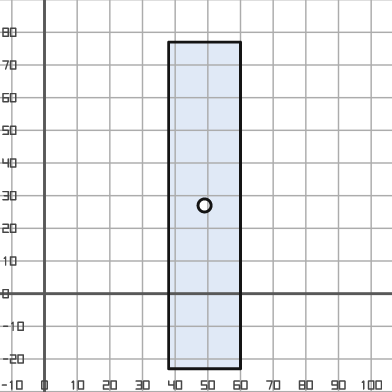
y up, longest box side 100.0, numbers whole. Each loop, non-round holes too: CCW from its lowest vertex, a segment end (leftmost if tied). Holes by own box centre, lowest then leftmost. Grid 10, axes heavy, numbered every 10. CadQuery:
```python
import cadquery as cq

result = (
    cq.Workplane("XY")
    .moveTo(38.0, -23.0)
    .lineTo(60.0, -23.0)
    .lineTo(60.0, 77.0)
    .lineTo(38.0, 77.0)
    .close()
    .moveTo(49.0, 27.0)
    .circle(2.0)
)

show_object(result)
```